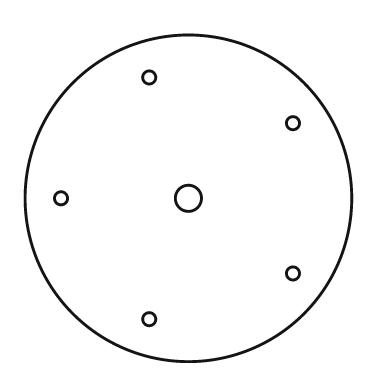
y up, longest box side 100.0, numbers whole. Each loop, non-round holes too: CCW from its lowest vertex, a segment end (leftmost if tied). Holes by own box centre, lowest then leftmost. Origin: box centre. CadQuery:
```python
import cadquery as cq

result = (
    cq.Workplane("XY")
    .moveTo(0.0, 0.0)
    .circle(50.0)
    .moveTo(-12.0, -37.0)
    .circle(2.0)
    .moveTo(32.0, -23.0)
    .circle(2.0)
    .moveTo(-39.0, 0.0)
    .circle(2.0)
    .moveTo(0.0, 0.0)
    .circle(4.0)
    .moveTo(32.0, 23.0)
    .circle(2.0)
    .moveTo(-12.0, 37.0)
    .circle(2.0)
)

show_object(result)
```